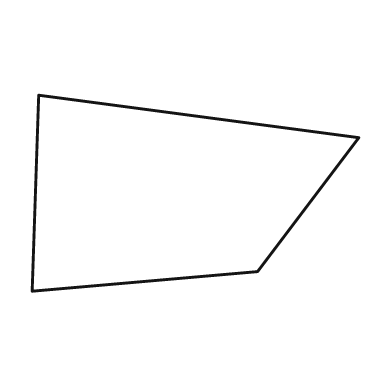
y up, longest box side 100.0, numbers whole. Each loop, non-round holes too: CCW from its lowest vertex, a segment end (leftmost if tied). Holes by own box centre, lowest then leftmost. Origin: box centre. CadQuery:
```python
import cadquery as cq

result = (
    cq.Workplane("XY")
    .moveTo(-50.0, -30.0)
    .lineTo(19.0, -24.0)
    .lineTo(50.0, 17.0)
    .lineTo(-48.0, 30.0)
    .close()
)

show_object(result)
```